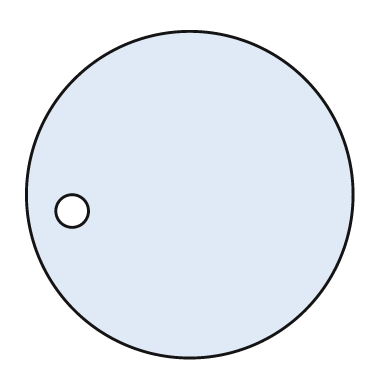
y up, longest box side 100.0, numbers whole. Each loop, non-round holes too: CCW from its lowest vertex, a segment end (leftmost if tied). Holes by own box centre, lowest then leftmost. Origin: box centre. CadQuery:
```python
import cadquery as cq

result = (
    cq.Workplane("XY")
    .moveTo(0.0, 0.0)
    .circle(50.0)
    .moveTo(-36.0, -5.0)
    .circle(5.0)
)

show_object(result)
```